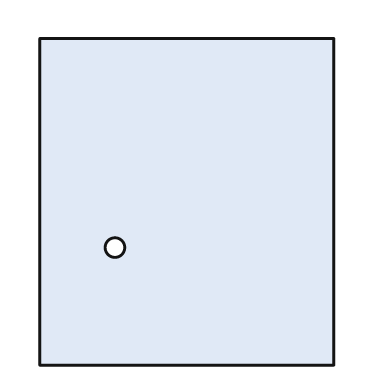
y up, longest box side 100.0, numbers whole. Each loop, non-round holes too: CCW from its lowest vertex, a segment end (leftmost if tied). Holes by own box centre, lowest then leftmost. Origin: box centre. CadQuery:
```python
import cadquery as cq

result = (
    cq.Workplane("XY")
    .moveTo(-45.0, -50.0)
    .lineTo(45.0, -50.0)
    .lineTo(45.0, 50.0)
    .lineTo(-45.0, 50.0)
    .close()
    .moveTo(-22.0, -14.0)
    .circle(3.0)
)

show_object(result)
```